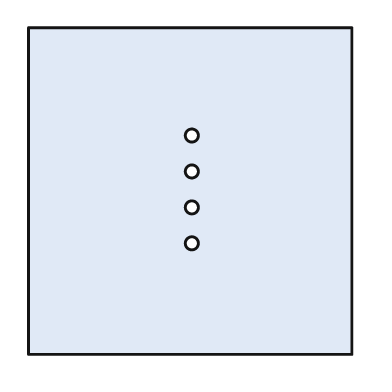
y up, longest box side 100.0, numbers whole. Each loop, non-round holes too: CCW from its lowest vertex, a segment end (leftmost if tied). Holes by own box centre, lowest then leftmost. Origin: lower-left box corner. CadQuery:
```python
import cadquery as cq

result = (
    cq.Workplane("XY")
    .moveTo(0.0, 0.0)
    .lineTo(99.0, 0.0)
    .lineTo(99.0, 100.0)
    .lineTo(0.0, 100.0)
    .close()
    .moveTo(50.0, 34.0)
    .circle(2.0)
    .moveTo(50.0, 45.0)
    .circle(2.0)
    .moveTo(50.0, 56.0)
    .circle(2.0)
    .moveTo(50.0, 67.0)
    .circle(2.0)
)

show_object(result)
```